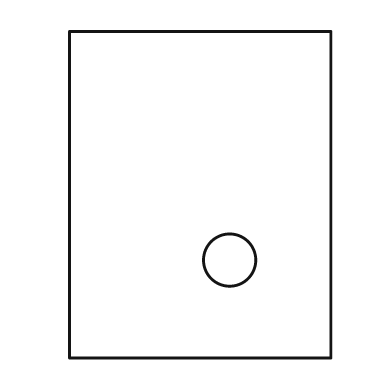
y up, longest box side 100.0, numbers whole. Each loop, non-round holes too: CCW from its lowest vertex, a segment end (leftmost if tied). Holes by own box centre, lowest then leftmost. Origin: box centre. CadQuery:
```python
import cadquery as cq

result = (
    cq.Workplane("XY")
    .moveTo(-40.0, -50.0)
    .lineTo(40.0, -50.0)
    .lineTo(40.0, 50.0)
    .lineTo(-40.0, 50.0)
    .close()
    .moveTo(9.0, -20.0)
    .circle(8.0)
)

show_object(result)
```